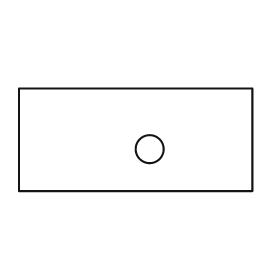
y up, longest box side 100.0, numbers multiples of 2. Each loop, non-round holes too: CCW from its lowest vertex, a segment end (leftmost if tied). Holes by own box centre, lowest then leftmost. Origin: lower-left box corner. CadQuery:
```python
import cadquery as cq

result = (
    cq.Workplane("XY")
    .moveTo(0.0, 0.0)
    .lineTo(100.0, 0.0)
    .lineTo(100.0, 44.0)
    .lineTo(0.0, 44.0)
    .close()
    .moveTo(56.0, 18.0)
    .circle(6.0)
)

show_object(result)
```